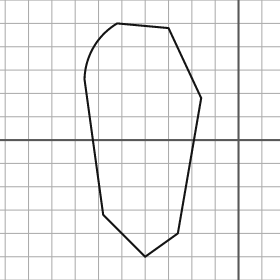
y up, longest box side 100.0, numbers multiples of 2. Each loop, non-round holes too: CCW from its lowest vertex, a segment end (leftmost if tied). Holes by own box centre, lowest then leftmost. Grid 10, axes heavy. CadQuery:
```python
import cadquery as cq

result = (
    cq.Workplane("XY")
    .moveTo(-40.0, -50.0)
    .lineTo(-26.0, -40.0)
    .lineTo(-16.0, 18.0)
    .lineTo(-30.0, 48.0)
    .lineTo(-52.0, 50.0)
    .threePointArc((-62.0, 40.0), (-66.0, 26.0))
    .lineTo(-58.0, -32.0)
    .close()
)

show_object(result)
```